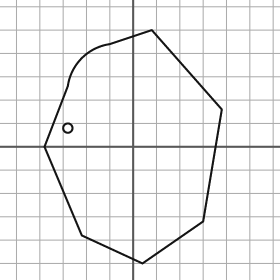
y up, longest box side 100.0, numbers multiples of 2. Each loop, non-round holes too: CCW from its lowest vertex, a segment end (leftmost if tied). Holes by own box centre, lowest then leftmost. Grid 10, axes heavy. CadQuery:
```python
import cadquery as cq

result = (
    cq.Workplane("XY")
    .moveTo(4.0, -50.0)
    .lineTo(30.0, -32.0)
    .lineTo(38.0, 16.0)
    .lineTo(8.0, 50.0)
    .lineTo(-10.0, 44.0)
    .threePointArc((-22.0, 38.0), (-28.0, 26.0))
    .lineTo(-38.0, 0.0)
    .lineTo(-22.0, -38.0)
    .close()
    .moveTo(-28.0, 8.0)
    .circle(2.0)
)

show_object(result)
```